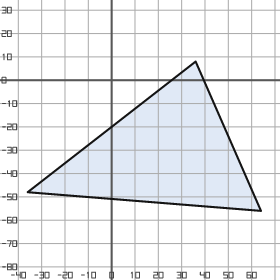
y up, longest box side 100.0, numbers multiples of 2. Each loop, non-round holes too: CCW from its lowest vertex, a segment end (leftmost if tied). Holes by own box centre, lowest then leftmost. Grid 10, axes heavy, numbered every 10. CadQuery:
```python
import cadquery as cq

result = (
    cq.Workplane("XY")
    .moveTo(64.0, -56.0)
    .lineTo(36.0, 8.0)
    .lineTo(-36.0, -48.0)
    .close()
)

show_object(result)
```